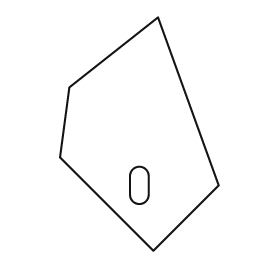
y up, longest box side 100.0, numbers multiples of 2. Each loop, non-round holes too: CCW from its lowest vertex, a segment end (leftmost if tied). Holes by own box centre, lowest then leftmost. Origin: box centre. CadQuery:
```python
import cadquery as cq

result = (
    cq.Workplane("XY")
    .moveTo(6.0, -50.0)
    .lineTo(34.0, -22.0)
    .lineTo(8.0, 50.0)
    .lineTo(-30.0, 20.0)
    .lineTo(-34.0, -10.0)
    .close()
    .moveTo(-4.0, -26.0)
    .threePointArc((0.0, -30.0), (4.0, -26.0))
    .lineTo(4.0, -18.0)
    .threePointArc((0.0, -14.0), (-4.0, -18.0))
    .close()
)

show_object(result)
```